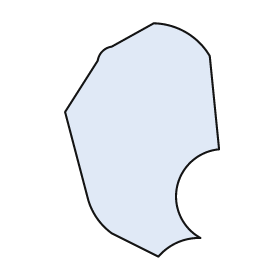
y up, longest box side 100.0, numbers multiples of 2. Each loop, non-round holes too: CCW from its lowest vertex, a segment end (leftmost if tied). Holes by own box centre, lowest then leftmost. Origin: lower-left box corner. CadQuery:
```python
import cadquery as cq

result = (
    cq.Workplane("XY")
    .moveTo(40.0, 0.0)
    .threePointArc((48.0, 6.0), (58.0, 8.0))
    .threePointArc((48.0, 30.0), (66.0, 46.0))
    .lineTo(62.0, 86.0)
    .threePointArc((52.0, 96.0), (38.0, 100.0))
    .lineTo(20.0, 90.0)
    .threePointArc((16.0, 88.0), (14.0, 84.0))
    .lineTo(0.0, 62.0)
    .lineTo(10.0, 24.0)
    .threePointArc((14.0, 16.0), (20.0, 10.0))
    .close()
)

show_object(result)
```